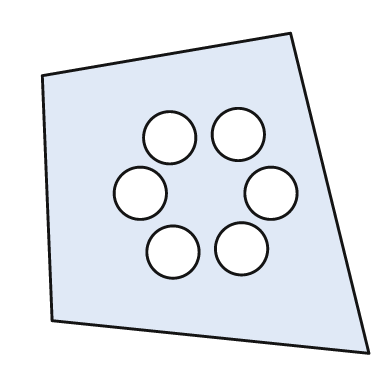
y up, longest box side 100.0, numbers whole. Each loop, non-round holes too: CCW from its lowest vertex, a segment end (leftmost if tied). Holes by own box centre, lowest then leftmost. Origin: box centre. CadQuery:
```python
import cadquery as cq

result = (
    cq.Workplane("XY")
    .moveTo(50.0, -49.0)
    .lineTo(26.0, 49.0)
    .lineTo(-50.0, 36.0)
    .lineTo(-47.0, -39.0)
    .close()
    .moveTo(-10.0, -18.0)
    .circle(8.0)
    .moveTo(11.0, -17.0)
    .circle(8.0)
    .moveTo(-20.0, 0.0)
    .circle(8.0)
    .moveTo(20.0, 0.0)
    .circle(8.0)
    .moveTo(-11.0, 17.0)
    .circle(8.0)
    .moveTo(10.0, 18.0)
    .circle(8.0)
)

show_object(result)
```